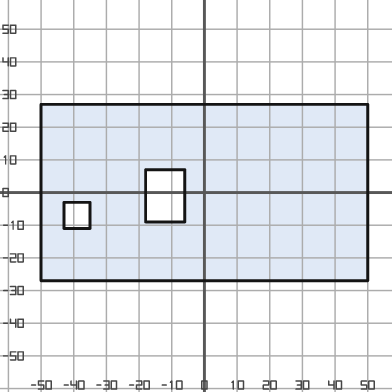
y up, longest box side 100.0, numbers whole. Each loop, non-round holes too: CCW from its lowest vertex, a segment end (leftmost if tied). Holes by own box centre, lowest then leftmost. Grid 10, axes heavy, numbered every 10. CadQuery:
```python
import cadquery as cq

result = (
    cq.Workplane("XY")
    .moveTo(-50.0, -27.0)
    .lineTo(50.0, -27.0)
    .lineTo(50.0, 27.0)
    .lineTo(-50.0, 27.0)
    .close()
    .moveTo(-43.0, -11.0)
    .lineTo(-35.0, -11.0)
    .lineTo(-35.0, -3.0)
    .lineTo(-43.0, -3.0)
    .close()
    .moveTo(-18.0, -9.0)
    .lineTo(-6.0, -9.0)
    .lineTo(-6.0, 7.0)
    .lineTo(-18.0, 7.0)
    .close()
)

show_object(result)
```